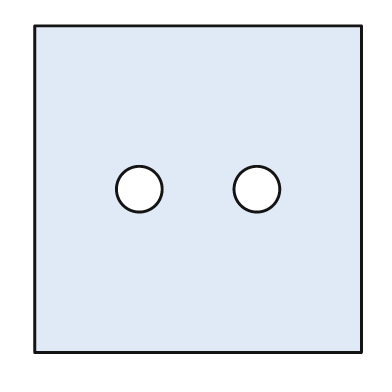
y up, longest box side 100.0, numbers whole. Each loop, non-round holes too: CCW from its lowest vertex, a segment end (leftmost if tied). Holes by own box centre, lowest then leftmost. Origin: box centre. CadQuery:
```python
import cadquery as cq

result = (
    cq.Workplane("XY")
    .moveTo(-50.0, -50.0)
    .lineTo(50.0, -50.0)
    .lineTo(50.0, 50.0)
    .lineTo(-50.0, 50.0)
    .close()
    .moveTo(-18.0, 0.0)
    .circle(7.0)
    .moveTo(18.0, 0.0)
    .circle(7.0)
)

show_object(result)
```